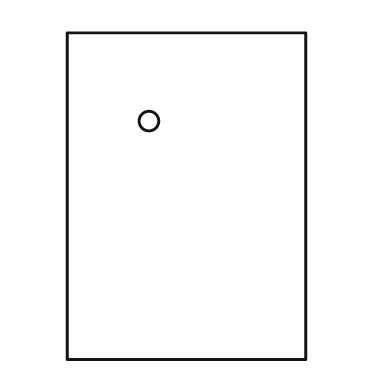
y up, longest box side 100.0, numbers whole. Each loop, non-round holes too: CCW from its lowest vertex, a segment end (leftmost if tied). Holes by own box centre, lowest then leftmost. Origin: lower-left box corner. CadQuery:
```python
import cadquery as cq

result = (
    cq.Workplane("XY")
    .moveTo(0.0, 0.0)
    .lineTo(73.0, 0.0)
    .lineTo(73.0, 100.0)
    .lineTo(0.0, 100.0)
    .close()
    .moveTo(25.0, 73.0)
    .circle(3.0)
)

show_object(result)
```